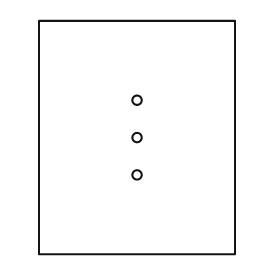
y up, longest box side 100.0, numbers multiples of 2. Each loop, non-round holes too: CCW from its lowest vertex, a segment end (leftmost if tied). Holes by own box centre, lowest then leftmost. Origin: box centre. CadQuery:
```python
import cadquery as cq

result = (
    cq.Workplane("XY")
    .moveTo(-42.0, -50.0)
    .lineTo(42.0, -50.0)
    .lineTo(42.0, 50.0)
    .lineTo(-42.0, 50.0)
    .close()
    .moveTo(0.0, -16.0)
    .circle(2.0)
    .moveTo(0.0, 0.0)
    .circle(2.0)
    .moveTo(0.0, 16.0)
    .circle(2.0)
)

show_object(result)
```